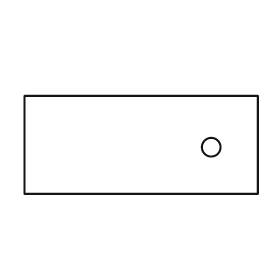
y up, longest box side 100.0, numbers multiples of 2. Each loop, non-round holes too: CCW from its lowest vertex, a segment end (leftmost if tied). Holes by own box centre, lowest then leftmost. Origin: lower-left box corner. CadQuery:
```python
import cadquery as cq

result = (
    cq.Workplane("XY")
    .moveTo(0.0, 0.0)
    .lineTo(100.0, 0.0)
    .lineTo(100.0, 42.0)
    .lineTo(0.0, 42.0)
    .close()
    .moveTo(80.0, 20.0)
    .circle(4.0)
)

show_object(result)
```